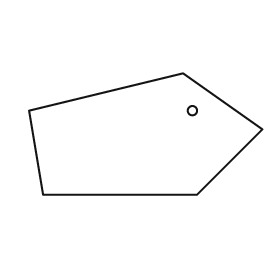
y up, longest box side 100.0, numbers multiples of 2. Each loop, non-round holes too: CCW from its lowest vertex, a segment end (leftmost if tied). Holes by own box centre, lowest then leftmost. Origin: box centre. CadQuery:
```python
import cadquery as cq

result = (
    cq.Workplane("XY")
    .moveTo(-44.0, -26.0)
    .lineTo(22.0, -26.0)
    .lineTo(50.0, 2.0)
    .lineTo(16.0, 26.0)
    .lineTo(-50.0, 10.0)
    .close()
    .moveTo(20.0, 10.0)
    .circle(2.0)
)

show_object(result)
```